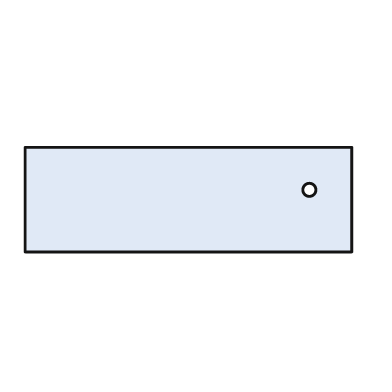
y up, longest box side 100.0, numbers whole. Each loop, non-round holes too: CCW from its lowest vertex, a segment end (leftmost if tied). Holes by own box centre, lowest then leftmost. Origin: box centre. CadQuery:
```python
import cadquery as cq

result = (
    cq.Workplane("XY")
    .moveTo(-50.0, -16.0)
    .lineTo(50.0, -16.0)
    .lineTo(50.0, 16.0)
    .lineTo(-50.0, 16.0)
    .close()
    .moveTo(37.0, 3.0)
    .circle(2.0)
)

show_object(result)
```